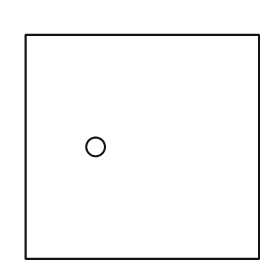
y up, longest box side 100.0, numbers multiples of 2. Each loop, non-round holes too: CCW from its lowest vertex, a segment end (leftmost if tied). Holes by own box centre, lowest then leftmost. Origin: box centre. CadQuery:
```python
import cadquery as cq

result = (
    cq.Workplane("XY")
    .moveTo(-50.0, -48.0)
    .lineTo(50.0, -48.0)
    .lineTo(50.0, 48.0)
    .lineTo(-50.0, 48.0)
    .close()
    .moveTo(-20.0, 0.0)
    .circle(4.0)
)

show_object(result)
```